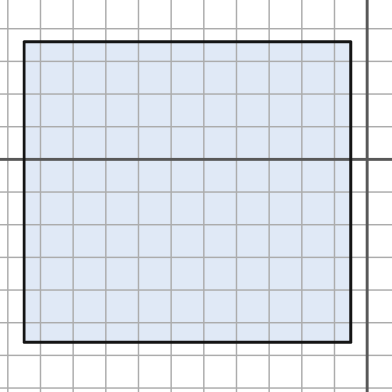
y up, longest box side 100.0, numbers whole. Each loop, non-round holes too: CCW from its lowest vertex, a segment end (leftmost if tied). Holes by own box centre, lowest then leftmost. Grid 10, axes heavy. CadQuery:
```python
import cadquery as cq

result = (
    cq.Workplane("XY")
    .moveTo(-105.0, -56.0)
    .lineTo(-5.0, -56.0)
    .lineTo(-5.0, 36.0)
    .lineTo(-105.0, 36.0)
    .close()
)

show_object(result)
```